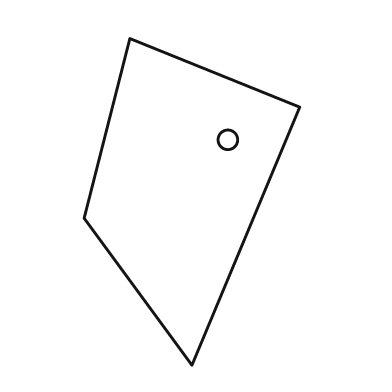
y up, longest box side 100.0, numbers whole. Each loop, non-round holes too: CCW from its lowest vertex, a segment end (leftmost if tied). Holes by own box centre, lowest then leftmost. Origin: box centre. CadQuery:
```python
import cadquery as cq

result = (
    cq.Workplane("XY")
    .moveTo(0.0, -50.0)
    .lineTo(33.0, 29.0)
    .lineTo(-19.0, 50.0)
    .lineTo(-33.0, -5.0)
    .close()
    .moveTo(11.0, 19.0)
    .circle(3.0)
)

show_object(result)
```